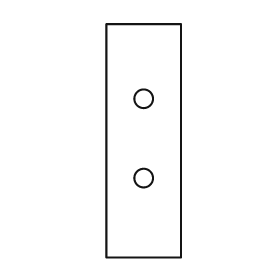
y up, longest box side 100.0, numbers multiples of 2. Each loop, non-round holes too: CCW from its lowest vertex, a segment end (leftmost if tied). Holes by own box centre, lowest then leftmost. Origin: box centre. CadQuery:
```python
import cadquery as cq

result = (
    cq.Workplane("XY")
    .moveTo(-16.0, -50.0)
    .lineTo(16.0, -50.0)
    .lineTo(16.0, 50.0)
    .lineTo(-16.0, 50.0)
    .close()
    .moveTo(0.0, -16.0)
    .circle(4.0)
    .moveTo(0.0, 18.0)
    .circle(4.0)
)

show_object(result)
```